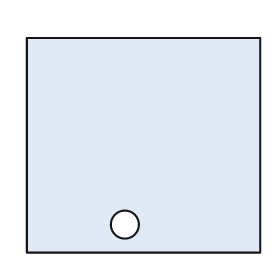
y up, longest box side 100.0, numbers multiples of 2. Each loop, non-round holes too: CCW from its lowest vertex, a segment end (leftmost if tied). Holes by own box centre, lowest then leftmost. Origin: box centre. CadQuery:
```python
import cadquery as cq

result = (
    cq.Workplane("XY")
    .moveTo(-50.0, -46.0)
    .lineTo(50.0, -46.0)
    .lineTo(50.0, 46.0)
    .lineTo(-50.0, 46.0)
    .close()
    .moveTo(-8.0, -34.0)
    .circle(6.0)
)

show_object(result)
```